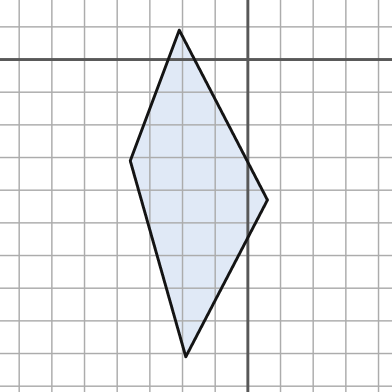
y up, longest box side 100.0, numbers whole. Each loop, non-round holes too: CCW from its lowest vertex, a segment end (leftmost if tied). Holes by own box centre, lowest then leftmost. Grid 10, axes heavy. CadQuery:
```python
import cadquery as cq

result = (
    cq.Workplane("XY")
    .moveTo(-19.0, -91.0)
    .lineTo(6.0, -43.0)
    .lineTo(-21.0, 9.0)
    .lineTo(-36.0, -31.0)
    .close()
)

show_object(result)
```